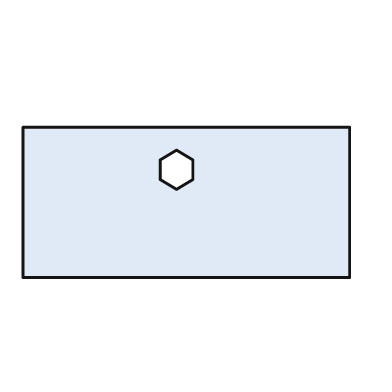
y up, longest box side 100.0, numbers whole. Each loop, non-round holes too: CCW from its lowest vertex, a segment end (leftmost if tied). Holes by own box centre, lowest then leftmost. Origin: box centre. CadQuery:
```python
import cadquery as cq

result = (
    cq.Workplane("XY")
    .moveTo(-50.0, -23.0)
    .lineTo(50.0, -23.0)
    .lineTo(50.0, 23.0)
    .lineTo(-50.0, 23.0)
    .close()
    .moveTo(-3.0, 4.0)
    .lineTo(2.0, 7.0)
    .lineTo(2.0, 13.0)
    .lineTo(-3.0, 16.0)
    .lineTo(-8.0, 13.0)
    .lineTo(-8.0, 7.0)
    .close()
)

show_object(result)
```